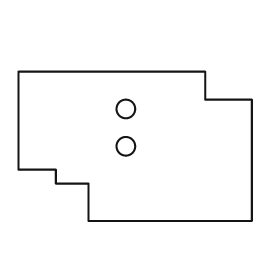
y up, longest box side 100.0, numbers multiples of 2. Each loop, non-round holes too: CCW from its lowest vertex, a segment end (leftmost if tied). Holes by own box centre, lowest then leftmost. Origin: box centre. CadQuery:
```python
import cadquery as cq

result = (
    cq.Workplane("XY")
    .moveTo(-20.0, -32.0)
    .lineTo(50.0, -32.0)
    .lineTo(50.0, 20.0)
    .lineTo(30.0, 20.0)
    .lineTo(30.0, 32.0)
    .lineTo(-50.0, 32.0)
    .lineTo(-50.0, -10.0)
    .lineTo(-34.0, -10.0)
    .lineTo(-34.0, -16.0)
    .lineTo(-20.0, -16.0)
    .close()
    .moveTo(-4.0, 0.0)
    .circle(4.0)
    .moveTo(-4.0, 16.0)
    .circle(4.0)
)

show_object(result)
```